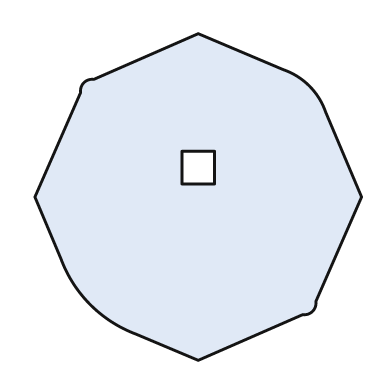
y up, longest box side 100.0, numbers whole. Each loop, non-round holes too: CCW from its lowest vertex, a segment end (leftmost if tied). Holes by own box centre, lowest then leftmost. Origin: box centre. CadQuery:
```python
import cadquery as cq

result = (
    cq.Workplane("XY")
    .moveTo(0.0, -50.0)
    .lineTo(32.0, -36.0)
    .threePointArc((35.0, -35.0), (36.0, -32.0))
    .lineTo(50.0, 0.0)
    .lineTo(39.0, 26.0)
    .threePointArc((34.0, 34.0), (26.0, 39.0))
    .lineTo(0.0, 50.0)
    .lineTo(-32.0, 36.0)
    .threePointArc((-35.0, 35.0), (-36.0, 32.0))
    .lineTo(-50.0, 0.0)
    .lineTo(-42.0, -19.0)
    .threePointArc((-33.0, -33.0), (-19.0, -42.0))
    .close()
    .moveTo(-5.0, 4.0)
    .lineTo(5.0, 4.0)
    .lineTo(5.0, 14.0)
    .lineTo(-5.0, 14.0)
    .close()
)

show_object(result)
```